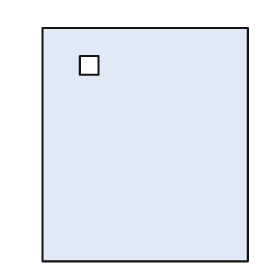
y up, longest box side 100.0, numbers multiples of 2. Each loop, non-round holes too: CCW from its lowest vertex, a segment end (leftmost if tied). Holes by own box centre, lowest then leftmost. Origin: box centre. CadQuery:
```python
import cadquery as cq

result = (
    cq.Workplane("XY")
    .moveTo(-44.0, -50.0)
    .lineTo(44.0, -50.0)
    .lineTo(44.0, 50.0)
    .lineTo(-44.0, 50.0)
    .close()
    .moveTo(-28.0, 30.0)
    .lineTo(-20.0, 30.0)
    .lineTo(-20.0, 38.0)
    .lineTo(-28.0, 38.0)
    .close()
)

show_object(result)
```